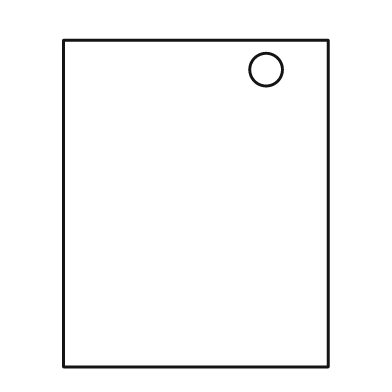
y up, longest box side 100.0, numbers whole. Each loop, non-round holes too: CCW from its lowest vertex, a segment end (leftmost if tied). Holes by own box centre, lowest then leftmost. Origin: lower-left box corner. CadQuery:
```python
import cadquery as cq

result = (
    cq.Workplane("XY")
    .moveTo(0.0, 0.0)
    .lineTo(81.0, 0.0)
    .lineTo(81.0, 100.0)
    .lineTo(0.0, 100.0)
    .close()
    .moveTo(62.0, 91.0)
    .circle(5.0)
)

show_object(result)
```